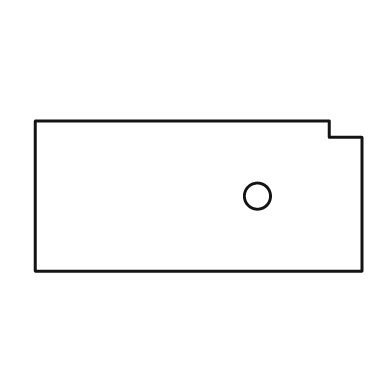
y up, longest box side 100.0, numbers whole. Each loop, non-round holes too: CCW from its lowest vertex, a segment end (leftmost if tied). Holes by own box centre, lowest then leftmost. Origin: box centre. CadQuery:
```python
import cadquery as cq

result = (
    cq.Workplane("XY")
    .moveTo(-50.0, -23.0)
    .lineTo(50.0, -23.0)
    .lineTo(50.0, 18.0)
    .lineTo(40.0, 18.0)
    .lineTo(40.0, 23.0)
    .lineTo(-50.0, 23.0)
    .close()
    .moveTo(18.0, 0.0)
    .circle(4.0)
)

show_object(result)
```